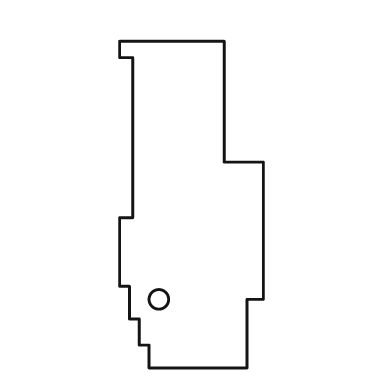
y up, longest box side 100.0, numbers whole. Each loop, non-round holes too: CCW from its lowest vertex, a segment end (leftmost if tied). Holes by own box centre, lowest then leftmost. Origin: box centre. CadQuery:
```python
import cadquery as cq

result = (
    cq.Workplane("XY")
    .moveTo(-13.0, -50.0)
    .lineTo(17.0, -50.0)
    .lineTo(17.0, -29.0)
    .lineTo(22.0, -29.0)
    .lineTo(22.0, 13.0)
    .lineTo(10.0, 13.0)
    .lineTo(10.0, 50.0)
    .lineTo(-22.0, 50.0)
    .lineTo(-22.0, 45.0)
    .lineTo(-18.0, 45.0)
    .lineTo(-18.0, -4.0)
    .lineTo(-22.0, -4.0)
    .lineTo(-22.0, -25.0)
    .lineTo(-19.0, -25.0)
    .lineTo(-19.0, -35.0)
    .lineTo(-16.0, -35.0)
    .lineTo(-16.0, -43.0)
    .lineTo(-13.0, -43.0)
    .close()
    .moveTo(-10.0, -29.0)
    .circle(3.0)
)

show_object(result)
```